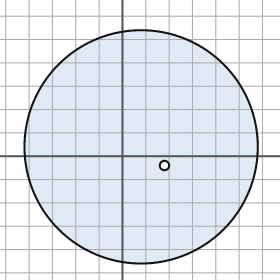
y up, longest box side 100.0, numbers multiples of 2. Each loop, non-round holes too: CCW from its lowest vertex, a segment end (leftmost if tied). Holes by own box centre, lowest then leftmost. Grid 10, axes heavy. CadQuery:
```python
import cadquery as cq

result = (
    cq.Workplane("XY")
    .moveTo(8.0, 4.0)
    .circle(50.0)
    .moveTo(18.0, -4.0)
    .circle(2.0)
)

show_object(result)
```